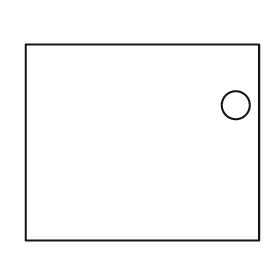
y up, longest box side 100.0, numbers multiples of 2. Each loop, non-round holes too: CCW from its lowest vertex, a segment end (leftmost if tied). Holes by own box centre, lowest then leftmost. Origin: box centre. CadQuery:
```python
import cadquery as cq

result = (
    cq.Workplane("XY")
    .moveTo(-50.0, -42.0)
    .lineTo(50.0, -42.0)
    .lineTo(50.0, 42.0)
    .lineTo(-50.0, 42.0)
    .close()
    .moveTo(40.0, 16.0)
    .circle(6.0)
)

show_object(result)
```